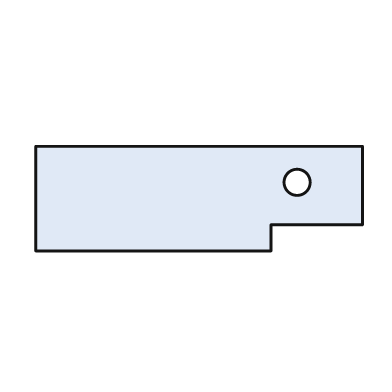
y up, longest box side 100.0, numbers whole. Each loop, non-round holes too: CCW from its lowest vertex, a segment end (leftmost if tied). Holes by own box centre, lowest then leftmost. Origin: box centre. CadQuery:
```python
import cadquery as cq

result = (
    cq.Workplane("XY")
    .moveTo(-50.0, -16.0)
    .lineTo(22.0, -16.0)
    .lineTo(22.0, -8.0)
    .lineTo(50.0, -8.0)
    .lineTo(50.0, 16.0)
    .lineTo(-50.0, 16.0)
    .close()
    .moveTo(30.0, 5.0)
    .circle(4.0)
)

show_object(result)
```